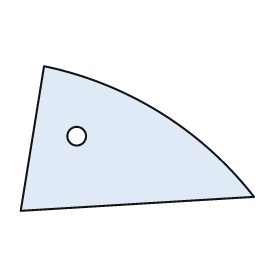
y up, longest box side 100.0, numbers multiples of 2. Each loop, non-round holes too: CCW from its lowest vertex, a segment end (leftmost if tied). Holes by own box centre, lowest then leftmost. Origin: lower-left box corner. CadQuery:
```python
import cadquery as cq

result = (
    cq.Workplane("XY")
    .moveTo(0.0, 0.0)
    .lineTo(100.0, 6.0)
    .threePointArc((60.0, 42.0), (10.0, 62.0))
    .close()
    .moveTo(24.0, 32.0)
    .circle(4.0)
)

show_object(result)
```